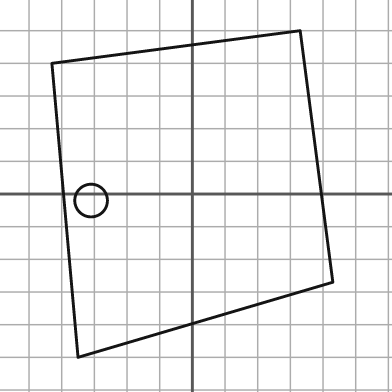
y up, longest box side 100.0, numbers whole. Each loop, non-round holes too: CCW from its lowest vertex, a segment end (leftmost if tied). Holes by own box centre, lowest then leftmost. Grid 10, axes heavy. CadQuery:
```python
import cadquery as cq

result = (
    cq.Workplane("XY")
    .moveTo(-35.0, -50.0)
    .lineTo(43.0, -27.0)
    .lineTo(33.0, 50.0)
    .lineTo(-43.0, 40.0)
    .close()
    .moveTo(-31.0, -2.0)
    .circle(5.0)
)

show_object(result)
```